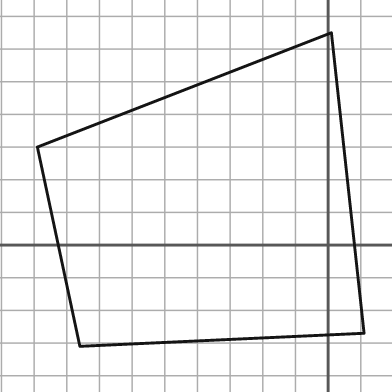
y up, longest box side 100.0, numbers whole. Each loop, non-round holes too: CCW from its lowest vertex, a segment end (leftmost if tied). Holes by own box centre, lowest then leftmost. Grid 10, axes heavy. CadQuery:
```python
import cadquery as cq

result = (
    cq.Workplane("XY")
    .moveTo(-76.0, -31.0)
    .lineTo(11.0, -27.0)
    .lineTo(1.0, 65.0)
    .lineTo(-89.0, 30.0)
    .close()
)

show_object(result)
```